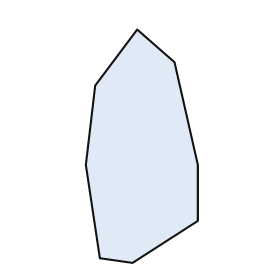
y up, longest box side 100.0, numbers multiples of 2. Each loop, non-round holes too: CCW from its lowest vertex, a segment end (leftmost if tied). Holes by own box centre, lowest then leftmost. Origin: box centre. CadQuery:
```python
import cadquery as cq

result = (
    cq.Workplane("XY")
    .moveTo(-4.0, -50.0)
    .lineTo(24.0, -32.0)
    .lineTo(24.0, -8.0)
    .lineTo(14.0, 36.0)
    .lineTo(-2.0, 50.0)
    .lineTo(-20.0, 26.0)
    .lineTo(-24.0, -8.0)
    .lineTo(-18.0, -48.0)
    .close()
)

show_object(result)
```